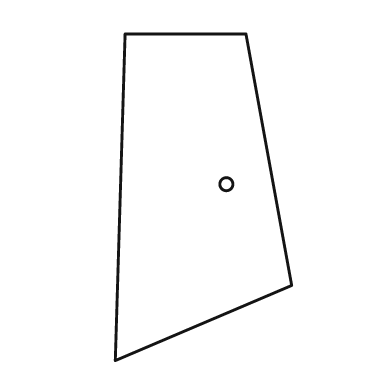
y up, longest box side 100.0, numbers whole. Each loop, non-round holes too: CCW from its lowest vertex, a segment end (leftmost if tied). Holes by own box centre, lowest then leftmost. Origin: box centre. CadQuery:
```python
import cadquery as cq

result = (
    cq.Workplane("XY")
    .moveTo(-27.0, -50.0)
    .lineTo(27.0, -27.0)
    .lineTo(13.0, 50.0)
    .lineTo(-24.0, 50.0)
    .close()
    .moveTo(7.0, 4.0)
    .circle(2.0)
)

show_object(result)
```